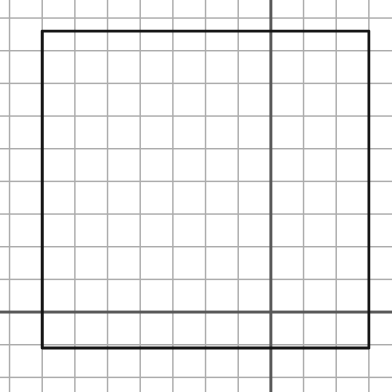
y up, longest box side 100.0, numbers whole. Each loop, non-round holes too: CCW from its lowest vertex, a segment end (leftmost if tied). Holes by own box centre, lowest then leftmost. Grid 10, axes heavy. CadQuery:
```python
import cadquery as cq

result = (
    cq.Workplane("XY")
    .moveTo(-70.0, -11.0)
    .lineTo(30.0, -11.0)
    .lineTo(30.0, 86.0)
    .lineTo(-70.0, 86.0)
    .close()
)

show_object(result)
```